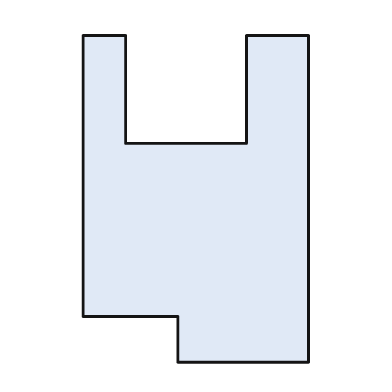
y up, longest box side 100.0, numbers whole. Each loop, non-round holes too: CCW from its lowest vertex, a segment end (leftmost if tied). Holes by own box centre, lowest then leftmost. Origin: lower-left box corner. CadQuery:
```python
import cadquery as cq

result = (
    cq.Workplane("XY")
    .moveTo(29.0, 0.0)
    .lineTo(69.0, 0.0)
    .lineTo(69.0, 100.0)
    .lineTo(50.0, 100.0)
    .lineTo(50.0, 67.0)
    .lineTo(13.0, 67.0)
    .lineTo(13.0, 100.0)
    .lineTo(0.0, 100.0)
    .lineTo(0.0, 14.0)
    .lineTo(29.0, 14.0)
    .close()
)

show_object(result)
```